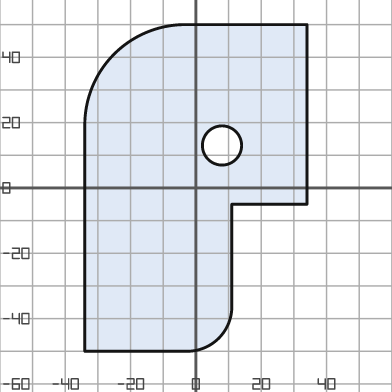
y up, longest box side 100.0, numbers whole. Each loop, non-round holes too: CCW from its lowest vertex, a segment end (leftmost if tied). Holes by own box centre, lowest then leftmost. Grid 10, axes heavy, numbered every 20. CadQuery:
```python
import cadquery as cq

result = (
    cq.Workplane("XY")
    .moveTo(-34.0, -50.0)
    .lineTo(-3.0, -50.0)
    .threePointArc((7.0, -46.0), (11.0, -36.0))
    .lineTo(11.0, -5.0)
    .lineTo(34.0, -5.0)
    .lineTo(34.0, 50.0)
    .lineTo(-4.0, 50.0)
    .threePointArc((-25.0, 41.0), (-34.0, 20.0))
    .close()
    .moveTo(8.0, 13.0)
    .circle(6.0)
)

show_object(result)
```